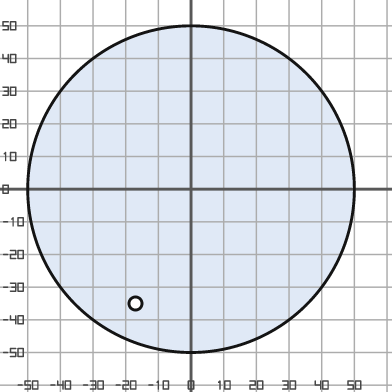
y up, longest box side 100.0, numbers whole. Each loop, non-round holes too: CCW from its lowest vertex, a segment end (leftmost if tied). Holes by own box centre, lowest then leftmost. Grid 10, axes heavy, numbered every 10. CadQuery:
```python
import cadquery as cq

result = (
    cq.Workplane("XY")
    .moveTo(0.0, 0.0)
    .circle(50.0)
    .moveTo(-17.0, -35.0)
    .circle(2.0)
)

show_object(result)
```